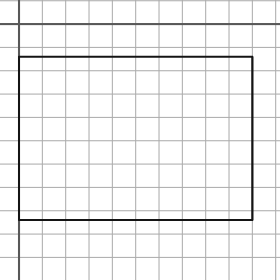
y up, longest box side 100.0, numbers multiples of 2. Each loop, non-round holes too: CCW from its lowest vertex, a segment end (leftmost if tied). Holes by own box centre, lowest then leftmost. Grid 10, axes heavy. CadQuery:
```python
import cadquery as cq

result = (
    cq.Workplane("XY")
    .moveTo(0.0, -84.0)
    .lineTo(100.0, -84.0)
    .lineTo(100.0, -14.0)
    .lineTo(0.0, -14.0)
    .close()
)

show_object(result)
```